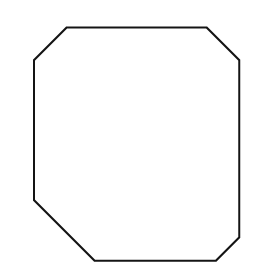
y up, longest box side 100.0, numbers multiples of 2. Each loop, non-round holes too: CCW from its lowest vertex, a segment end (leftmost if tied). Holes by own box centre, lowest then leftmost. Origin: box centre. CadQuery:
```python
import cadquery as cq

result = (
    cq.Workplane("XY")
    .moveTo(-18.0, -50.0)
    .lineTo(34.0, -50.0)
    .lineTo(44.0, -40.0)
    .lineTo(44.0, 36.0)
    .lineTo(30.0, 50.0)
    .lineTo(-30.0, 50.0)
    .lineTo(-44.0, 36.0)
    .lineTo(-44.0, -24.0)
    .close()
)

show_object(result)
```